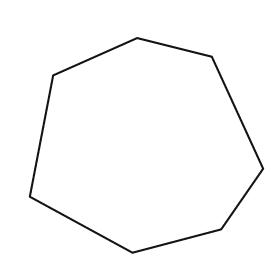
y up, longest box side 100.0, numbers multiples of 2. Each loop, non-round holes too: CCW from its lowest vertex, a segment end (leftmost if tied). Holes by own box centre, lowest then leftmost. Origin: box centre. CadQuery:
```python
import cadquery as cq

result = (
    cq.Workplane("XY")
    .moveTo(-6.0, -46.0)
    .lineTo(32.0, -36.0)
    .lineTo(50.0, -10.0)
    .lineTo(28.0, 38.0)
    .lineTo(-4.0, 46.0)
    .lineTo(-40.0, 30.0)
    .lineTo(-50.0, -22.0)
    .close()
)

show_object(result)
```